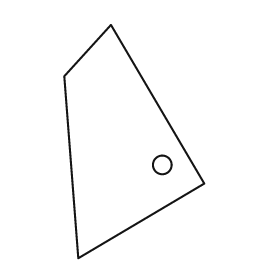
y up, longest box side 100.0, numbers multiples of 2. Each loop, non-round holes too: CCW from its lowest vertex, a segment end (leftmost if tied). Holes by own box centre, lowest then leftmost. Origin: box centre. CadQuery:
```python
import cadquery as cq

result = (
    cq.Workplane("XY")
    .moveTo(-24.0, -50.0)
    .lineTo(30.0, -18.0)
    .lineTo(-10.0, 50.0)
    .lineTo(-30.0, 28.0)
    .close()
    .moveTo(12.0, -10.0)
    .circle(4.0)
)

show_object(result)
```